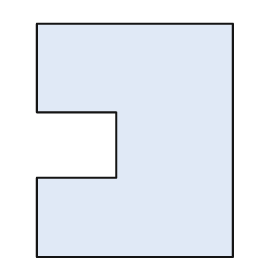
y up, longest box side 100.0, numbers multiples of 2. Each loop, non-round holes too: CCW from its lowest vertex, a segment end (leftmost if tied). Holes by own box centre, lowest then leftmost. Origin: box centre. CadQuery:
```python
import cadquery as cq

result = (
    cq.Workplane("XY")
    .moveTo(-42.0, -50.0)
    .lineTo(42.0, -50.0)
    .lineTo(42.0, 50.0)
    .lineTo(-42.0, 50.0)
    .lineTo(-42.0, 12.0)
    .lineTo(-8.0, 12.0)
    .lineTo(-8.0, -16.0)
    .lineTo(-42.0, -16.0)
    .close()
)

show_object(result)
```